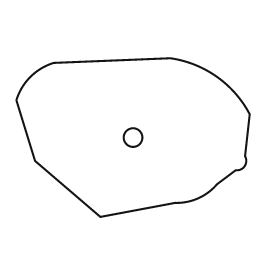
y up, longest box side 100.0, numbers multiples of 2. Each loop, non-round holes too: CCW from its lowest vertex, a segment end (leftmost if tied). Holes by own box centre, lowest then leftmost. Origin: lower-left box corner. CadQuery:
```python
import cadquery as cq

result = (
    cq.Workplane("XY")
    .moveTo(36.0, 0.0)
    .lineTo(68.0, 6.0)
    .threePointArc((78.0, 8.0), (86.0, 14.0))
    .lineTo(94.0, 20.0)
    .threePointArc((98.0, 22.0), (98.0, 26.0))
    .lineTo(100.0, 44.0)
    .threePointArc((86.0, 60.0), (66.0, 68.0))
    .lineTo(16.0, 66.0)
    .threePointArc((6.0, 60.0), (0.0, 50.0))
    .lineTo(8.0, 24.0)
    .close()
    .moveTo(50.0, 34.0)
    .circle(4.0)
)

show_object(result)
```